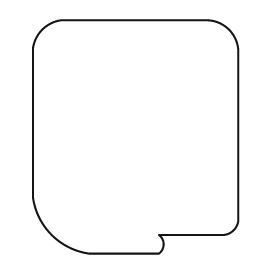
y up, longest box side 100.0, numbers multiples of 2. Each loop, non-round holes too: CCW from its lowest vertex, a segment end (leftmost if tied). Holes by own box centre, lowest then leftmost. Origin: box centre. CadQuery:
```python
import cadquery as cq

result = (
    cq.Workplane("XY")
    .moveTo(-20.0, -50.0)
    .lineTo(10.0, -50.0)
    .threePointArc((12.0, -46.0), (10.0, -42.0))
    .lineTo(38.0, -42.0)
    .threePointArc((42.0, -40.0), (44.0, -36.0))
    .lineTo(44.0, 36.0)
    .threePointArc((40.0, 46.0), (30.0, 50.0))
    .lineTo(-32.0, 50.0)
    .threePointArc((-40.0, 46.0), (-44.0, 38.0))
    .lineTo(-44.0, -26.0)
    .threePointArc((-36.0, -42.0), (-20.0, -50.0))
    .close()
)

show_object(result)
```